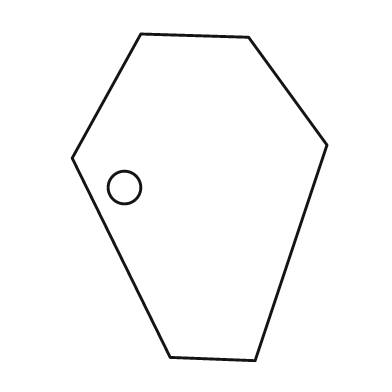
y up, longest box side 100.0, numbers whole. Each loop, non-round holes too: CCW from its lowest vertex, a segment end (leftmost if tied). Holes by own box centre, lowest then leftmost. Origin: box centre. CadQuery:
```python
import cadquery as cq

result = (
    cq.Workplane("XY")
    .moveTo(17.0, -50.0)
    .lineTo(39.0, 16.0)
    .lineTo(15.0, 49.0)
    .lineTo(-18.0, 50.0)
    .lineTo(-39.0, 12.0)
    .lineTo(-9.0, -49.0)
    .close()
    .moveTo(-23.0, 3.0)
    .circle(5.0)
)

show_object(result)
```